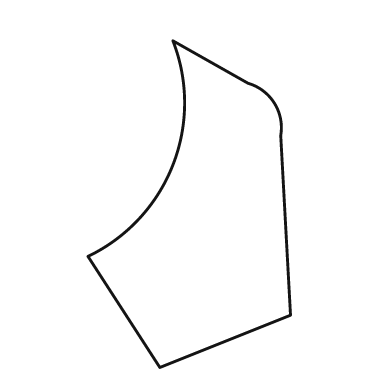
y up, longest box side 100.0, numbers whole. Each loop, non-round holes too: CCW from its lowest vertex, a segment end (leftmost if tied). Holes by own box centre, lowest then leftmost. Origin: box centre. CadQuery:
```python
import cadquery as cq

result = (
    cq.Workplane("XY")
    .moveTo(-9.0, -50.0)
    .lineTo(31.0, -34.0)
    .lineTo(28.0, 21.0)
    .threePointArc((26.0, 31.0), (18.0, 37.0))
    .lineTo(-5.0, 50.0)
    .threePointArc((-5.0, 12.0), (-31.0, -16.0))
    .close()
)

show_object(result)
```